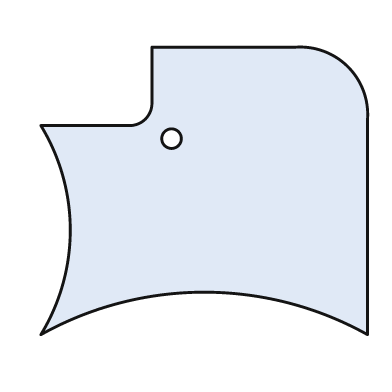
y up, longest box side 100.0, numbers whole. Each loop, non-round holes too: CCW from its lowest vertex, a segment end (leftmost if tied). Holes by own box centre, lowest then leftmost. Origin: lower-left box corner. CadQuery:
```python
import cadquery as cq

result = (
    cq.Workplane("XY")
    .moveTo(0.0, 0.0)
    .threePointArc((50.0, 13.0), (100.0, 0.0))
    .lineTo(100.0, 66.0)
    .threePointArc((94.0, 82.0), (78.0, 88.0))
    .lineTo(34.0, 88.0)
    .lineTo(34.0, 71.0)
    .threePointArc((32.0, 66.0), (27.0, 64.0))
    .lineTo(0.0, 64.0)
    .threePointArc((9.0, 32.0), (0.0, 0.0))
    .close()
    .moveTo(40.0, 60.0)
    .circle(3.0)
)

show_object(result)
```